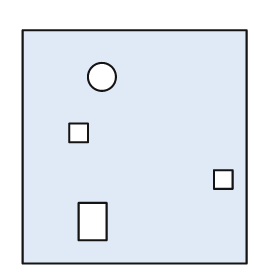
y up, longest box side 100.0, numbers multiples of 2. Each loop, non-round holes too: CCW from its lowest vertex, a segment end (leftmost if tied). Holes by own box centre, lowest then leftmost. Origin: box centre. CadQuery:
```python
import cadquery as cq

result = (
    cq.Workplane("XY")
    .moveTo(-48.0, -50.0)
    .lineTo(48.0, -50.0)
    .lineTo(48.0, 50.0)
    .lineTo(-48.0, 50.0)
    .close()
    .moveTo(-24.0, -40.0)
    .lineTo(-12.0, -40.0)
    .lineTo(-12.0, -24.0)
    .lineTo(-24.0, -24.0)
    .close()
    .moveTo(34.0, -18.0)
    .lineTo(42.0, -18.0)
    .lineTo(42.0, -10.0)
    .lineTo(34.0, -10.0)
    .close()
    .moveTo(-28.0, 2.0)
    .lineTo(-20.0, 2.0)
    .lineTo(-20.0, 10.0)
    .lineTo(-28.0, 10.0)
    .close()
    .moveTo(-14.0, 30.0)
    .circle(6.0)
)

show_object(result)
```